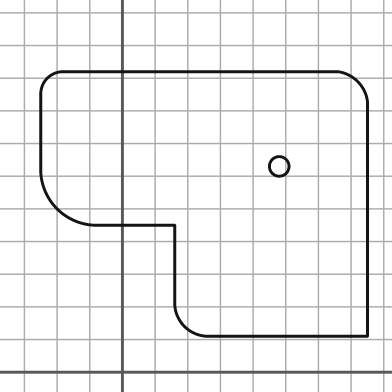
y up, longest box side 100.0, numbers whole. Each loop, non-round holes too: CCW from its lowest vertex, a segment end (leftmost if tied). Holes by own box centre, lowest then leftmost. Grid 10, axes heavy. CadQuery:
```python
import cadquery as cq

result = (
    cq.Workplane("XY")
    .moveTo(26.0, 11.0)
    .lineTo(75.0, 11.0)
    .lineTo(75.0, 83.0)
    .threePointArc((72.0, 89.0), (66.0, 92.0))
    .lineTo(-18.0, 92.0)
    .threePointArc((-23.0, 90.0), (-25.0, 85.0))
    .lineTo(-25.0, 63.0)
    .threePointArc((-20.0, 50.0), (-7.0, 45.0))
    .lineTo(16.0, 45.0)
    .lineTo(16.0, 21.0)
    .threePointArc((19.0, 14.0), (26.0, 11.0))
    .close()
    .moveTo(48.0, 63.0)
    .circle(3.0)
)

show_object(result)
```